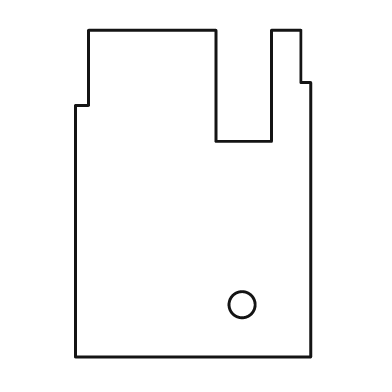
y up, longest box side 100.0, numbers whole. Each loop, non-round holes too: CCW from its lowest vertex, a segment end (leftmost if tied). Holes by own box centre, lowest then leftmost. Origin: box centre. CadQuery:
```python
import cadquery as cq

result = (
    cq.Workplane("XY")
    .moveTo(-36.0, -50.0)
    .lineTo(36.0, -50.0)
    .lineTo(36.0, 34.0)
    .lineTo(33.0, 34.0)
    .lineTo(33.0, 50.0)
    .lineTo(24.0, 50.0)
    .lineTo(24.0, 16.0)
    .lineTo(7.0, 16.0)
    .lineTo(7.0, 50.0)
    .lineTo(-32.0, 50.0)
    .lineTo(-32.0, 27.0)
    .lineTo(-36.0, 27.0)
    .close()
    .moveTo(15.0, -34.0)
    .circle(4.0)
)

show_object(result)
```